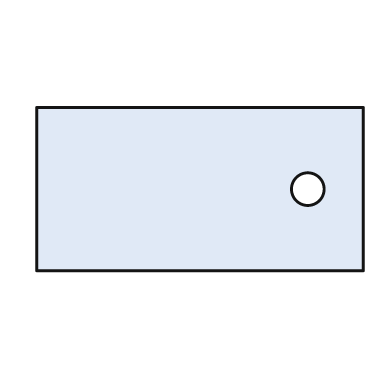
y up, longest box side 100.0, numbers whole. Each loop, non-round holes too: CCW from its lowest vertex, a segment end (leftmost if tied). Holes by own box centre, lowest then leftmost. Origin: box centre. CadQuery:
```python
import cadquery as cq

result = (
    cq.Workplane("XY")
    .moveTo(-50.0, -25.0)
    .lineTo(50.0, -25.0)
    .lineTo(50.0, 25.0)
    .lineTo(-50.0, 25.0)
    .close()
    .moveTo(33.0, 0.0)
    .circle(5.0)
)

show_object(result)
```